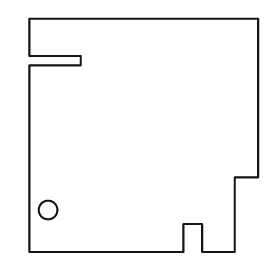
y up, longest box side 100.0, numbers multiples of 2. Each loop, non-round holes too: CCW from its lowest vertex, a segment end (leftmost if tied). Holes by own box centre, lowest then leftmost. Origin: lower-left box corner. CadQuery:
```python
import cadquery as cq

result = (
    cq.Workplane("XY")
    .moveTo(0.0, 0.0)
    .lineTo(66.0, 0.0)
    .lineTo(66.0, 12.0)
    .lineTo(74.0, 12.0)
    .lineTo(74.0, 0.0)
    .lineTo(88.0, 0.0)
    .lineTo(88.0, 32.0)
    .lineTo(98.0, 32.0)
    .lineTo(98.0, 100.0)
    .lineTo(0.0, 100.0)
    .lineTo(0.0, 84.0)
    .lineTo(22.0, 84.0)
    .lineTo(22.0, 80.0)
    .lineTo(0.0, 80.0)
    .close()
    .moveTo(8.0, 18.0)
    .circle(4.0)
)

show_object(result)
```